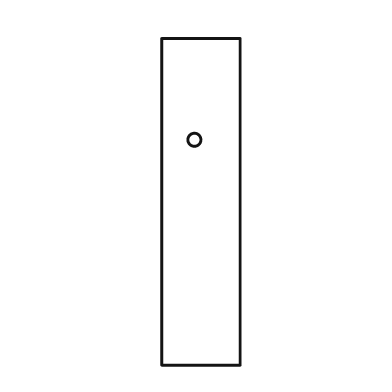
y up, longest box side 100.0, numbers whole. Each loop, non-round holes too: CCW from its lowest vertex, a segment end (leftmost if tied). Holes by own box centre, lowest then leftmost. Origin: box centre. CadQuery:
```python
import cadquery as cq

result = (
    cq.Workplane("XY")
    .moveTo(-12.0, -50.0)
    .lineTo(12.0, -50.0)
    .lineTo(12.0, 50.0)
    .lineTo(-12.0, 50.0)
    .close()
    .moveTo(-2.0, 19.0)
    .circle(2.0)
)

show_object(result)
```